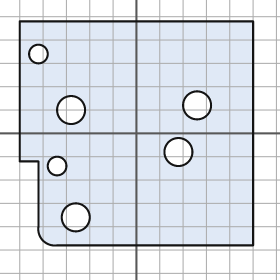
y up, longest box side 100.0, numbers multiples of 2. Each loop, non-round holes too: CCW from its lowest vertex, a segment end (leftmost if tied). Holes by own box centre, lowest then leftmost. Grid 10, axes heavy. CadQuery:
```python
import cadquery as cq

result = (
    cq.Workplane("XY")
    .moveTo(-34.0, -48.0)
    .lineTo(50.0, -48.0)
    .lineTo(50.0, 48.0)
    .lineTo(-50.0, 48.0)
    .lineTo(-50.0, -12.0)
    .lineTo(-42.0, -12.0)
    .lineTo(-42.0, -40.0)
    .threePointArc((-40.0, -46.0), (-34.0, -48.0))
    .close()
    .moveTo(-26.0, -36.0)
    .circle(6.0)
    .moveTo(-34.0, -14.0)
    .circle(4.0)
    .moveTo(18.0, -8.0)
    .circle(6.0)
    .moveTo(-28.0, 10.0)
    .circle(6.0)
    .moveTo(26.0, 12.0)
    .circle(6.0)
    .moveTo(-42.0, 34.0)
    .circle(4.0)
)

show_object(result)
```